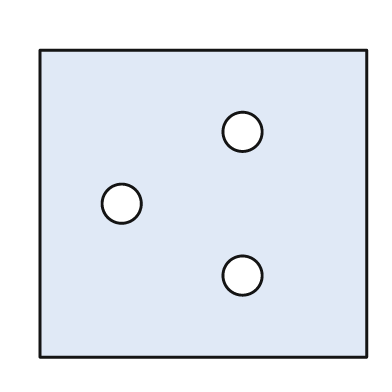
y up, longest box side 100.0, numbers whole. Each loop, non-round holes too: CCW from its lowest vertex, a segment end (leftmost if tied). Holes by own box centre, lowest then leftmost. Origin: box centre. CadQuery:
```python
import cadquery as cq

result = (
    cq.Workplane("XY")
    .moveTo(-50.0, -47.0)
    .lineTo(50.0, -47.0)
    .lineTo(50.0, 47.0)
    .lineTo(-50.0, 47.0)
    .close()
    .moveTo(12.0, -22.0)
    .circle(6.0)
    .moveTo(-25.0, 0.0)
    .circle(6.0)
    .moveTo(12.0, 22.0)
    .circle(6.0)
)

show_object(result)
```